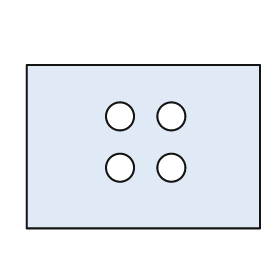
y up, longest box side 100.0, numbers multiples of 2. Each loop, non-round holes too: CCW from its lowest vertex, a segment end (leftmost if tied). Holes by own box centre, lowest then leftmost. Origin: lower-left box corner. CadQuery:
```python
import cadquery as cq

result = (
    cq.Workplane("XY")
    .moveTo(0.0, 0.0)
    .lineTo(100.0, 0.0)
    .lineTo(100.0, 70.0)
    .lineTo(0.0, 70.0)
    .close()
    .moveTo(40.0, 26.0)
    .circle(6.0)
    .moveTo(62.0, 26.0)
    .circle(6.0)
    .moveTo(40.0, 48.0)
    .circle(6.0)
    .moveTo(62.0, 48.0)
    .circle(6.0)
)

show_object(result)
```